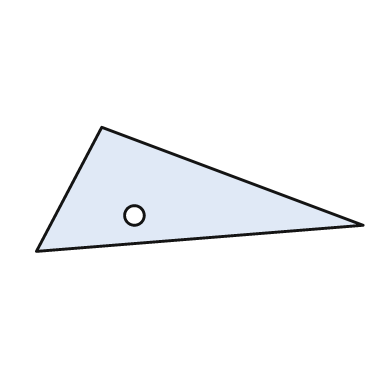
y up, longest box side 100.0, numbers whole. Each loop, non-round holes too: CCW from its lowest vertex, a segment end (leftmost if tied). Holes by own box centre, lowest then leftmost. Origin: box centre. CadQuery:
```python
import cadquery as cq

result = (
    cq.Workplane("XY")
    .moveTo(-50.0, -19.0)
    .lineTo(50.0, -11.0)
    .lineTo(-30.0, 19.0)
    .close()
    .moveTo(-20.0, -8.0)
    .circle(3.0)
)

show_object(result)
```